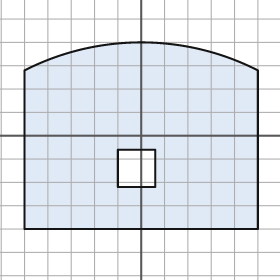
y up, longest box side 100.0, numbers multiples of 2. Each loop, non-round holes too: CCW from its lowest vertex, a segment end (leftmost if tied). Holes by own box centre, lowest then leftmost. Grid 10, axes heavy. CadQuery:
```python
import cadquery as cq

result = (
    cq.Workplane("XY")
    .moveTo(-50.0, -40.0)
    .lineTo(50.0, -40.0)
    .lineTo(50.0, 28.0)
    .threePointArc((0.0, 40.0), (-50.0, 28.0))
    .close()
    .moveTo(-10.0, -22.0)
    .lineTo(6.0, -22.0)
    .lineTo(6.0, -6.0)
    .lineTo(-10.0, -6.0)
    .close()
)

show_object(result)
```